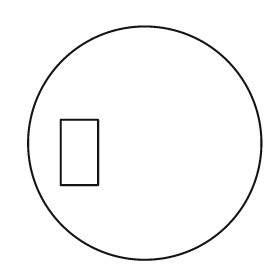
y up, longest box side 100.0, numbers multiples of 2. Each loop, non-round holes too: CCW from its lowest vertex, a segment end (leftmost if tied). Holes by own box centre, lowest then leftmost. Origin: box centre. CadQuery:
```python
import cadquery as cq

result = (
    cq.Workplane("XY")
    .moveTo(0.0, 0.0)
    .circle(50.0)
    .moveTo(-36.0, -18.0)
    .lineTo(-20.0, -18.0)
    .lineTo(-20.0, 10.0)
    .lineTo(-36.0, 10.0)
    .close()
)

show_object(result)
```